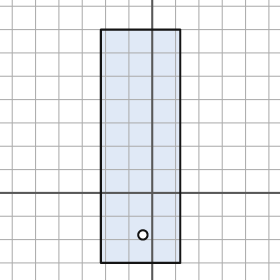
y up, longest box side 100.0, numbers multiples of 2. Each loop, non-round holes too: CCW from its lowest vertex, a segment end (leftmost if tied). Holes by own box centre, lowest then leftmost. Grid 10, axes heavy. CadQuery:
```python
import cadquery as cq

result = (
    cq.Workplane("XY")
    .moveTo(-22.0, -30.0)
    .lineTo(12.0, -30.0)
    .lineTo(12.0, 70.0)
    .lineTo(-22.0, 70.0)
    .close()
    .moveTo(-4.0, -18.0)
    .circle(2.0)
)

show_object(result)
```